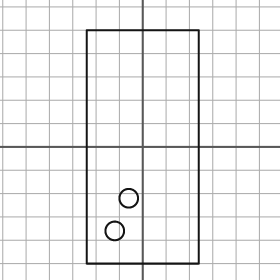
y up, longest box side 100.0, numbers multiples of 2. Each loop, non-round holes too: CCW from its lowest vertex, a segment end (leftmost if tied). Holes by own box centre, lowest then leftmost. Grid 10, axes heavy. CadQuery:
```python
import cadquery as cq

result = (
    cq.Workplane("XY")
    .moveTo(-24.0, -50.0)
    .lineTo(24.0, -50.0)
    .lineTo(24.0, 50.0)
    .lineTo(-24.0, 50.0)
    .close()
    .moveTo(-12.0, -36.0)
    .circle(4.0)
    .moveTo(-6.0, -22.0)
    .circle(4.0)
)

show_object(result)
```